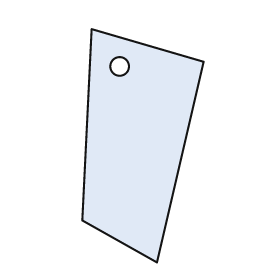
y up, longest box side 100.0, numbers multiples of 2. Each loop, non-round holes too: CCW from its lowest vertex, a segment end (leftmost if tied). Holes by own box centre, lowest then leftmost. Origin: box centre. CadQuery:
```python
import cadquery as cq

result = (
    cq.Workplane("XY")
    .moveTo(6.0, -50.0)
    .lineTo(26.0, 36.0)
    .lineTo(-22.0, 50.0)
    .lineTo(-26.0, -32.0)
    .close()
    .moveTo(-10.0, 34.0)
    .circle(4.0)
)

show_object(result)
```